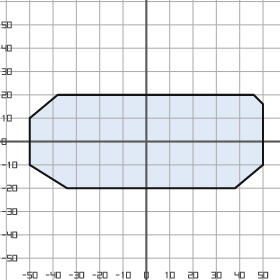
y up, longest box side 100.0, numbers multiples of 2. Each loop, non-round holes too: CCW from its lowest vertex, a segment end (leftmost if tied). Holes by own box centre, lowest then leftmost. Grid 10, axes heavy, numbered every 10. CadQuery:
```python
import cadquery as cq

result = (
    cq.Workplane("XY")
    .moveTo(-34.0, -20.0)
    .lineTo(38.0, -20.0)
    .lineTo(50.0, -10.0)
    .lineTo(50.0, 16.0)
    .lineTo(46.0, 20.0)
    .lineTo(-38.0, 20.0)
    .lineTo(-50.0, 10.0)
    .lineTo(-50.0, -10.0)
    .close()
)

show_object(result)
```